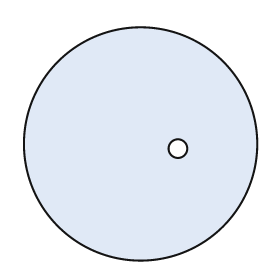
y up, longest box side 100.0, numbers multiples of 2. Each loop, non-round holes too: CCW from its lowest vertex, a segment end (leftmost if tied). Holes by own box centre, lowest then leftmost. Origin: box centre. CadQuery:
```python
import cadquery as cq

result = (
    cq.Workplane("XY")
    .moveTo(0.0, 0.0)
    .circle(50.0)
    .moveTo(16.0, -2.0)
    .circle(4.0)
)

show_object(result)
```